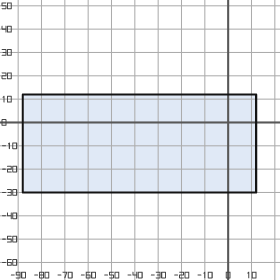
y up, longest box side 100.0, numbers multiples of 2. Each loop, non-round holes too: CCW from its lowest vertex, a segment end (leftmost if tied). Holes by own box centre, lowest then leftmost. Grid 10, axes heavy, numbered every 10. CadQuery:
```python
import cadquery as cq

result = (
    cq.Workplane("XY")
    .moveTo(-88.0, -30.0)
    .lineTo(12.0, -30.0)
    .lineTo(12.0, 12.0)
    .lineTo(-88.0, 12.0)
    .close()
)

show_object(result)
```